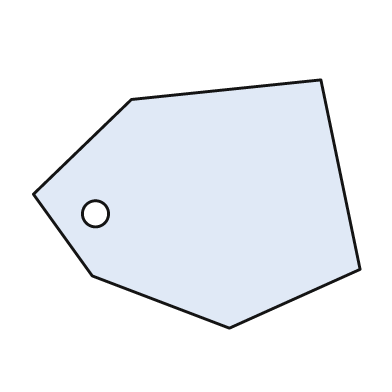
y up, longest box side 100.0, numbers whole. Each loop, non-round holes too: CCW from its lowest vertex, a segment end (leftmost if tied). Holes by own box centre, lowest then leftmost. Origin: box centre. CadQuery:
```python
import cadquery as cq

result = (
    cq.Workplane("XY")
    .moveTo(10.0, -38.0)
    .lineTo(50.0, -20.0)
    .lineTo(38.0, 38.0)
    .lineTo(-20.0, 32.0)
    .lineTo(-50.0, 3.0)
    .lineTo(-32.0, -22.0)
    .close()
    .moveTo(-31.0, -3.0)
    .circle(4.0)
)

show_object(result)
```